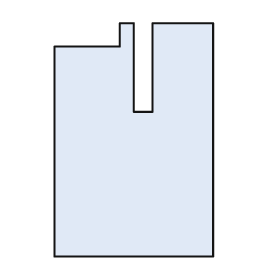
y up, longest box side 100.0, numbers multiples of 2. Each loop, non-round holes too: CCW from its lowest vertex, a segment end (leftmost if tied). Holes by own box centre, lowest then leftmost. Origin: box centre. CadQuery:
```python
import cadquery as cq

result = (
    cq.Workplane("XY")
    .moveTo(-34.0, -50.0)
    .lineTo(34.0, -50.0)
    .lineTo(34.0, 50.0)
    .lineTo(8.0, 50.0)
    .lineTo(8.0, 12.0)
    .lineTo(0.0, 12.0)
    .lineTo(0.0, 50.0)
    .lineTo(-6.0, 50.0)
    .lineTo(-6.0, 40.0)
    .lineTo(-34.0, 40.0)
    .close()
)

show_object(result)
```